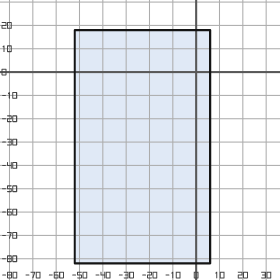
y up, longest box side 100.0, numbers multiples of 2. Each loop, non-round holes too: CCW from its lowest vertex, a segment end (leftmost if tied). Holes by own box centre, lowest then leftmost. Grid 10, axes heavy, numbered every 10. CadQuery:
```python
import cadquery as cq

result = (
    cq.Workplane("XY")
    .moveTo(-52.0, -82.0)
    .lineTo(6.0, -82.0)
    .lineTo(6.0, 18.0)
    .lineTo(-52.0, 18.0)
    .close()
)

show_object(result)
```